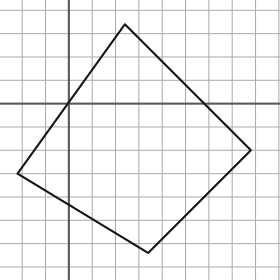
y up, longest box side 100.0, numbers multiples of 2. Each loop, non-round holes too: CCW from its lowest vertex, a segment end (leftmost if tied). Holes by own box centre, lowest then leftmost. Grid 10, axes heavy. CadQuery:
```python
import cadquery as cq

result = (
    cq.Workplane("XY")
    .moveTo(34.0, -64.0)
    .lineTo(78.0, -20.0)
    .lineTo(24.0, 34.0)
    .lineTo(-22.0, -30.0)
    .close()
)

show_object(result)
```